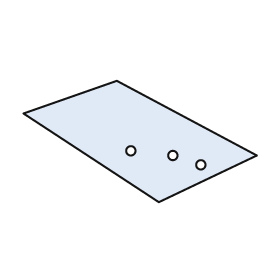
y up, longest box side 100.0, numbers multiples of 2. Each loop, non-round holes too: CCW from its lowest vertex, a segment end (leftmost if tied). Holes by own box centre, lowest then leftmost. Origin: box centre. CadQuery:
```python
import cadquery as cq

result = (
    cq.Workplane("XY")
    .moveTo(8.0, -26.0)
    .lineTo(50.0, -6.0)
    .lineTo(-10.0, 26.0)
    .lineTo(-50.0, 12.0)
    .close()
    .moveTo(26.0, -10.0)
    .circle(2.0)
    .moveTo(14.0, -6.0)
    .circle(2.0)
    .moveTo(-4.0, -4.0)
    .circle(2.0)
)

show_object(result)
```